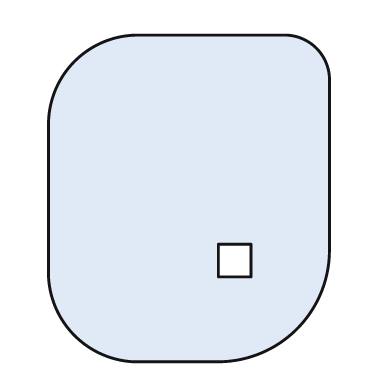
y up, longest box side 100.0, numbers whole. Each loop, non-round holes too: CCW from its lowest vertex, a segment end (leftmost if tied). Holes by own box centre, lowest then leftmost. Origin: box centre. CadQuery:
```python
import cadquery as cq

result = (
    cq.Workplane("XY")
    .moveTo(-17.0, -50.0)
    .lineTo(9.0, -50.0)
    .threePointArc((33.0, -40.0), (43.0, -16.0))
    .lineTo(43.0, 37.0)
    .threePointArc((39.0, 46.0), (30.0, 50.0))
    .lineTo(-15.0, 50.0)
    .threePointArc((-35.0, 42.0), (-43.0, 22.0))
    .lineTo(-43.0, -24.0)
    .threePointArc((-35.0, -42.0), (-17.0, -50.0))
    .close()
    .moveTo(9.0, -24.0)
    .lineTo(19.0, -24.0)
    .lineTo(19.0, -14.0)
    .lineTo(9.0, -14.0)
    .close()
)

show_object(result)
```